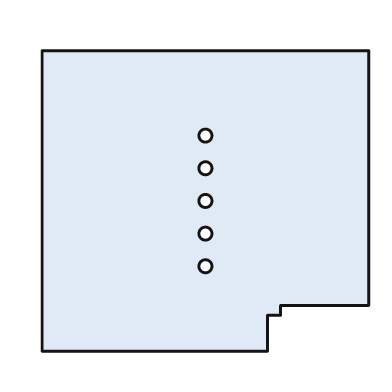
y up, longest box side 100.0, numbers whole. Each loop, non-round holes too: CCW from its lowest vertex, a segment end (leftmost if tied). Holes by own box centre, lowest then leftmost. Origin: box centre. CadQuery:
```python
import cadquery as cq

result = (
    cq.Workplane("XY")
    .moveTo(-50.0, -46.0)
    .lineTo(19.0, -46.0)
    .lineTo(19.0, -35.0)
    .lineTo(23.0, -35.0)
    .lineTo(23.0, -32.0)
    .lineTo(50.0, -32.0)
    .lineTo(50.0, 46.0)
    .lineTo(-50.0, 46.0)
    .close()
    .moveTo(0.0, -20.0)
    .circle(2.0)
    .moveTo(0.0, -10.0)
    .circle(2.0)
    .moveTo(0.0, 0.0)
    .circle(2.0)
    .moveTo(0.0, 10.0)
    .circle(2.0)
    .moveTo(0.0, 20.0)
    .circle(2.0)
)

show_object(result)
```